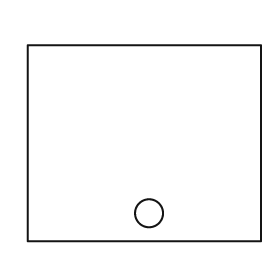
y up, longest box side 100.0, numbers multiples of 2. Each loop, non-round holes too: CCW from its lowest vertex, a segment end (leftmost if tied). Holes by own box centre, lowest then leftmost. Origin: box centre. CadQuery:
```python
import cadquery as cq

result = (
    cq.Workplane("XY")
    .moveTo(-50.0, -42.0)
    .lineTo(50.0, -42.0)
    .lineTo(50.0, 42.0)
    .lineTo(-50.0, 42.0)
    .close()
    .moveTo(2.0, -30.0)
    .circle(6.0)
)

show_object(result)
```